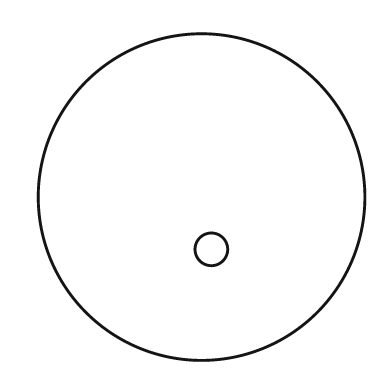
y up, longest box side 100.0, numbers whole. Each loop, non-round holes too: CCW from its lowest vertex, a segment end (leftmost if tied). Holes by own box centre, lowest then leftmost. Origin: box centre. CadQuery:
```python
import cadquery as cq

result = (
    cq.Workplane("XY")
    .moveTo(0.0, 0.0)
    .circle(50.0)
    .moveTo(3.0, -16.0)
    .circle(5.0)
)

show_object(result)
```